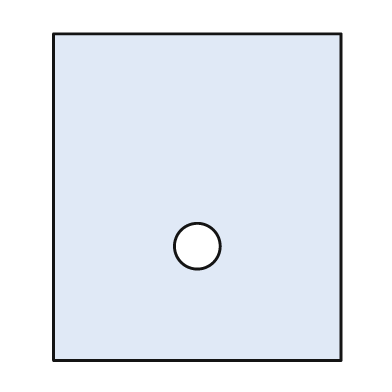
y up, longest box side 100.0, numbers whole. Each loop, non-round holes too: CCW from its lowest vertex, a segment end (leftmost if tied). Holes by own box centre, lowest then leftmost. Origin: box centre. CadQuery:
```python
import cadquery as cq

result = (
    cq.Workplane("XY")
    .moveTo(-44.0, -50.0)
    .lineTo(44.0, -50.0)
    .lineTo(44.0, 50.0)
    .lineTo(-44.0, 50.0)
    .close()
    .moveTo(0.0, -15.0)
    .circle(7.0)
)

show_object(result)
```